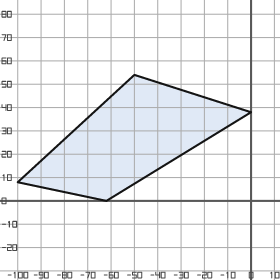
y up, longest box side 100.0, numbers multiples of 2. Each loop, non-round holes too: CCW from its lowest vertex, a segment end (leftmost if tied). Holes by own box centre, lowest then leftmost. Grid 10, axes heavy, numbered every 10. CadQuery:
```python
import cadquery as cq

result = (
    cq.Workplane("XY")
    .moveTo(-62.0, 0.0)
    .lineTo(0.0, 38.0)
    .lineTo(-50.0, 54.0)
    .lineTo(-100.0, 8.0)
    .close()
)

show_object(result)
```